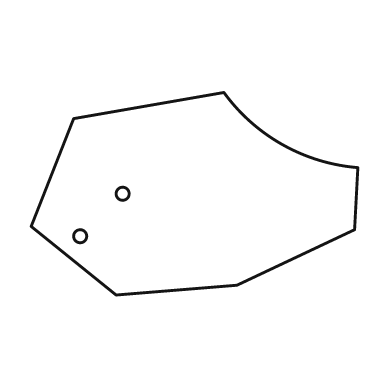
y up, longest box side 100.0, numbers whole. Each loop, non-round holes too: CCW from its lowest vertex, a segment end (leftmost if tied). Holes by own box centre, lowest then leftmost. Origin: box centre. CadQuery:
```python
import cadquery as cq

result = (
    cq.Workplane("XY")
    .moveTo(-24.0, -31.0)
    .lineTo(13.0, -28.0)
    .lineTo(49.0, -11.0)
    .lineTo(50.0, 8.0)
    .threePointArc((27.0, 15.0), (9.0, 31.0))
    .lineTo(-37.0, 23.0)
    .lineTo(-50.0, -10.0)
    .close()
    .moveTo(-35.0, -13.0)
    .circle(2.0)
    .moveTo(-22.0, 0.0)
    .circle(2.0)
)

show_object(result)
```